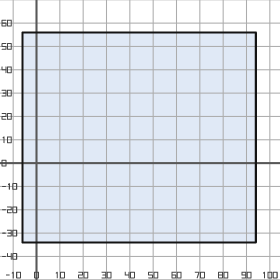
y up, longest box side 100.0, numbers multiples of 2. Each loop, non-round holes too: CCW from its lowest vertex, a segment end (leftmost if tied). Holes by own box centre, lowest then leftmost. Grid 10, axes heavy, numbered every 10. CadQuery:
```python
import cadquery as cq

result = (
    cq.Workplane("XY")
    .moveTo(-6.0, -34.0)
    .lineTo(94.0, -34.0)
    .lineTo(94.0, 56.0)
    .lineTo(-6.0, 56.0)
    .close()
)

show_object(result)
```